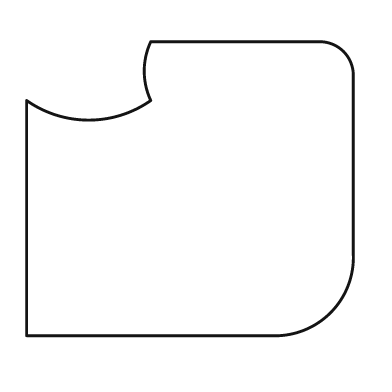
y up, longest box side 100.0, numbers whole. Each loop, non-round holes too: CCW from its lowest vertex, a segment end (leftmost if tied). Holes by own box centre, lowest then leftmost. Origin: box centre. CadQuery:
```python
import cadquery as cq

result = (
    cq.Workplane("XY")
    .moveTo(-50.0, -45.0)
    .lineTo(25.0, -45.0)
    .threePointArc((43.0, -38.0), (50.0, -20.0))
    .lineTo(50.0, 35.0)
    .threePointArc((47.0, 42.0), (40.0, 45.0))
    .lineTo(-12.0, 45.0)
    .threePointArc((-14.0, 36.0), (-12.0, 27.0))
    .threePointArc((-31.0, 21.0), (-50.0, 27.0))
    .close()
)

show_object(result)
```